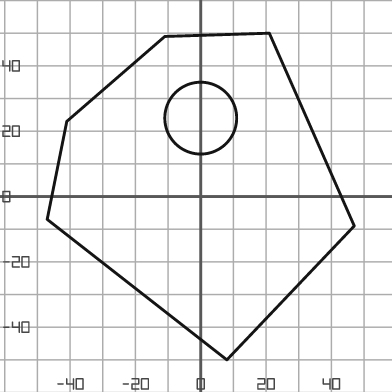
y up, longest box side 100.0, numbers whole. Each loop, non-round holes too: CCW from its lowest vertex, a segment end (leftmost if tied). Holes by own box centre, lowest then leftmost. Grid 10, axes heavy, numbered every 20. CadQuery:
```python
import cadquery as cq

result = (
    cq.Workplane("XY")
    .moveTo(8.0, -50.0)
    .lineTo(47.0, -9.0)
    .lineTo(21.0, 50.0)
    .lineTo(-11.0, 49.0)
    .lineTo(-41.0, 23.0)
    .lineTo(-47.0, -7.0)
    .close()
    .moveTo(0.0, 24.0)
    .circle(11.0)
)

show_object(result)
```